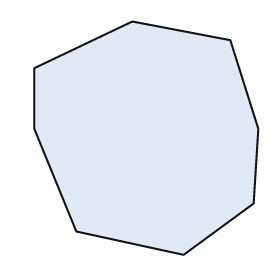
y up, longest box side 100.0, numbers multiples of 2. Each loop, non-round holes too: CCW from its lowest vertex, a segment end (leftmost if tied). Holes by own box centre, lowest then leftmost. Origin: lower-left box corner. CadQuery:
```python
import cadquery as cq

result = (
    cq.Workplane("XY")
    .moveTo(64.0, 0.0)
    .lineTo(94.0, 22.0)
    .lineTo(96.0, 54.0)
    .lineTo(84.0, 92.0)
    .lineTo(42.0, 100.0)
    .lineTo(0.0, 80.0)
    .lineTo(0.0, 54.0)
    .lineTo(18.0, 10.0)
    .close()
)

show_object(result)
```